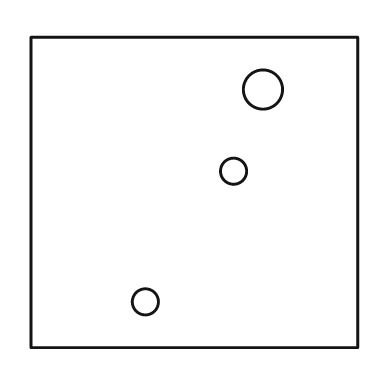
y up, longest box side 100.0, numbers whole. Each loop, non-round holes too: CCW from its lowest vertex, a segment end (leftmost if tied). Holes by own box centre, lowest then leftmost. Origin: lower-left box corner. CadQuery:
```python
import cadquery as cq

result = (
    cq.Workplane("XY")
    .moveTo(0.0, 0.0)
    .lineTo(100.0, 0.0)
    .lineTo(100.0, 95.0)
    .lineTo(0.0, 95.0)
    .close()
    .moveTo(35.0, 14.0)
    .circle(4.0)
    .moveTo(62.0, 54.0)
    .circle(4.0)
    .moveTo(71.0, 79.0)
    .circle(6.0)
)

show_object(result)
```